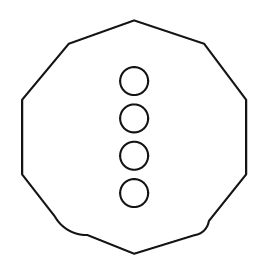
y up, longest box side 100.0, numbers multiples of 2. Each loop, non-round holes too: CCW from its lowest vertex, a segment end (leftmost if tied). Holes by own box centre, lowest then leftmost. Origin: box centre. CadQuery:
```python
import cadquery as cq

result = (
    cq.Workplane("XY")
    .moveTo(0.0, -50.0)
    .lineTo(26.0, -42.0)
    .threePointArc((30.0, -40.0), (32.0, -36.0))
    .lineTo(48.0, -16.0)
    .lineTo(48.0, 16.0)
    .lineTo(30.0, 40.0)
    .lineTo(0.0, 50.0)
    .lineTo(-28.0, 40.0)
    .lineTo(-48.0, 16.0)
    .lineTo(-48.0, -16.0)
    .lineTo(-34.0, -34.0)
    .threePointArc((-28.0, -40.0), (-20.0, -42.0))
    .close()
    .moveTo(0.0, -24.0)
    .circle(6.0)
    .moveTo(0.0, -8.0)
    .circle(6.0)
    .moveTo(0.0, 8.0)
    .circle(6.0)
    .moveTo(0.0, 24.0)
    .circle(6.0)
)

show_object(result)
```